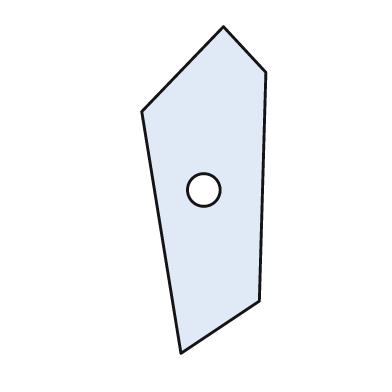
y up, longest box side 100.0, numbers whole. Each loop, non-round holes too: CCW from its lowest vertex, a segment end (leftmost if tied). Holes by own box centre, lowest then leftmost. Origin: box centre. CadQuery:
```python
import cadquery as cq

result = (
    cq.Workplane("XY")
    .moveTo(-7.0, -50.0)
    .lineTo(17.0, -34.0)
    .lineTo(19.0, 36.0)
    .lineTo(6.0, 50.0)
    .lineTo(-19.0, 24.0)
    .close()
    .moveTo(0.0, 0.0)
    .circle(5.0)
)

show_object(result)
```